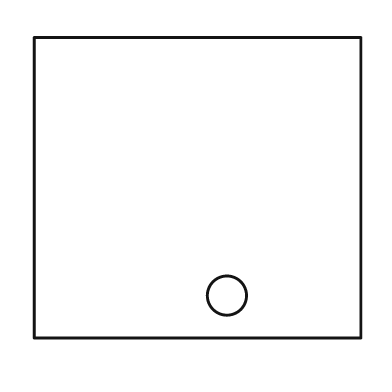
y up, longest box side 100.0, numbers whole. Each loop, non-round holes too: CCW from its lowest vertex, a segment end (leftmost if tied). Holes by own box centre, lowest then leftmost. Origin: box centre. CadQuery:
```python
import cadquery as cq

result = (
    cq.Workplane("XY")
    .moveTo(-50.0, -46.0)
    .lineTo(50.0, -46.0)
    .lineTo(50.0, 46.0)
    .lineTo(-50.0, 46.0)
    .close()
    .moveTo(9.0, -33.0)
    .circle(6.0)
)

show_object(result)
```